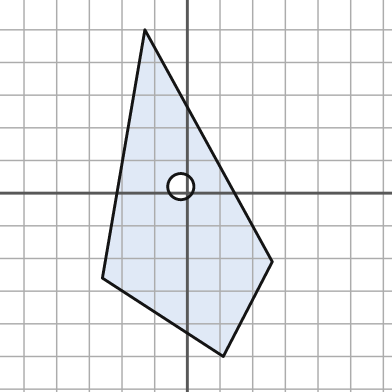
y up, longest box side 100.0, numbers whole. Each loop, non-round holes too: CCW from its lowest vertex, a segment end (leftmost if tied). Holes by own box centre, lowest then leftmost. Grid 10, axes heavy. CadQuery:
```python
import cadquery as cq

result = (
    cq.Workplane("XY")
    .moveTo(11.0, -50.0)
    .lineTo(26.0, -21.0)
    .lineTo(-13.0, 50.0)
    .lineTo(-26.0, -26.0)
    .close()
    .moveTo(-2.0, 2.0)
    .circle(4.0)
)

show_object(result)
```